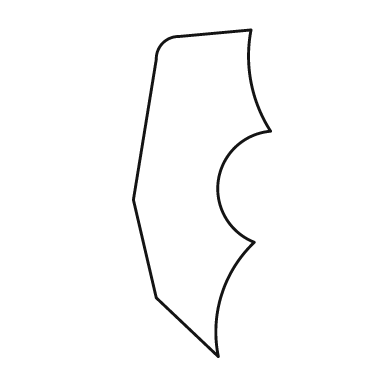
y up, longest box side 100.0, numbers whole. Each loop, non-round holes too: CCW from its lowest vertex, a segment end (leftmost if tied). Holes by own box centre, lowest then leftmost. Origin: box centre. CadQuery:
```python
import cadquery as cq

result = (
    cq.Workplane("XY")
    .moveTo(5.0, -50.0)
    .threePointArc((6.0, -31.0), (16.0, -15.0))
    .threePointArc((5.0, 4.0), (21.0, 19.0))
    .threePointArc((15.0, 34.0), (15.0, 50.0))
    .lineTo(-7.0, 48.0)
    .threePointArc((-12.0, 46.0), (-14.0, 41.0))
    .lineTo(-21.0, -2.0)
    .lineTo(-14.0, -32.0)
    .close()
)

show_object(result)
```